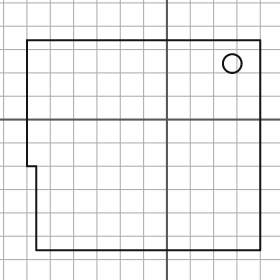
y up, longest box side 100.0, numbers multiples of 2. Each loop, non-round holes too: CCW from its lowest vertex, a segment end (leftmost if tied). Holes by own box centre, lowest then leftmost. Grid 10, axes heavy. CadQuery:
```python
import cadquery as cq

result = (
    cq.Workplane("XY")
    .moveTo(-56.0, -56.0)
    .lineTo(40.0, -56.0)
    .lineTo(40.0, 34.0)
    .lineTo(-60.0, 34.0)
    .lineTo(-60.0, -20.0)
    .lineTo(-56.0, -20.0)
    .close()
    .moveTo(28.0, 24.0)
    .circle(4.0)
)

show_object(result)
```